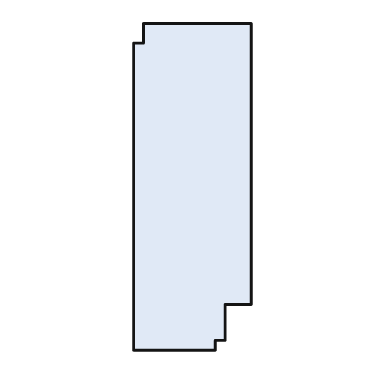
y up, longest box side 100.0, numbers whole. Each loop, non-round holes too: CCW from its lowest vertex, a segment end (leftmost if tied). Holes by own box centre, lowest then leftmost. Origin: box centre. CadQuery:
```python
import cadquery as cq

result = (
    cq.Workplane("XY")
    .moveTo(-18.0, -50.0)
    .lineTo(7.0, -50.0)
    .lineTo(7.0, -47.0)
    .lineTo(10.0, -47.0)
    .lineTo(10.0, -36.0)
    .lineTo(18.0, -36.0)
    .lineTo(18.0, 50.0)
    .lineTo(-15.0, 50.0)
    .lineTo(-15.0, 44.0)
    .lineTo(-18.0, 44.0)
    .close()
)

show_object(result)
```